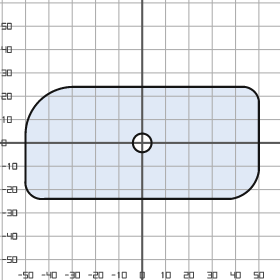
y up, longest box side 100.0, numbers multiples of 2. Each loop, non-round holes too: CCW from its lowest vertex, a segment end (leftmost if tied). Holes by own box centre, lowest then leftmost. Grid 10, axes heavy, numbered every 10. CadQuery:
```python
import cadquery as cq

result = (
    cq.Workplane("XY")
    .moveTo(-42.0, -24.0)
    .lineTo(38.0, -24.0)
    .threePointArc((46.0, -20.0), (50.0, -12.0))
    .lineTo(50.0, 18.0)
    .threePointArc((48.0, 22.0), (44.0, 24.0))
    .lineTo(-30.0, 24.0)
    .threePointArc((-44.0, 18.0), (-50.0, 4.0))
    .lineTo(-50.0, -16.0)
    .threePointArc((-48.0, -22.0), (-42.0, -24.0))
    .close()
    .moveTo(0.0, 0.0)
    .circle(4.0)
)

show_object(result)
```